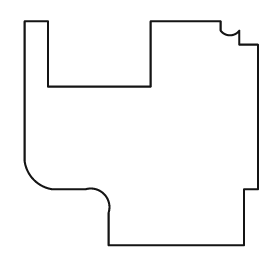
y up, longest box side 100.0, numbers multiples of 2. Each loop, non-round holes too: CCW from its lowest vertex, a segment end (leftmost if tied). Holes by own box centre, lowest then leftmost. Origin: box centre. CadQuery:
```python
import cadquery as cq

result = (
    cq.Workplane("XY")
    .moveTo(-14.0, -48.0)
    .lineTo(44.0, -48.0)
    .lineTo(44.0, -24.0)
    .lineTo(50.0, -24.0)
    .lineTo(50.0, 38.0)
    .lineTo(42.0, 38.0)
    .lineTo(42.0, 44.0)
    .threePointArc((38.0, 42.0), (34.0, 44.0))
    .lineTo(34.0, 48.0)
    .lineTo(4.0, 48.0)
    .lineTo(4.0, 20.0)
    .lineTo(-40.0, 20.0)
    .lineTo(-40.0, 48.0)
    .lineTo(-50.0, 48.0)
    .lineTo(-50.0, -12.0)
    .threePointArc((-46.0, -20.0), (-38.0, -24.0))
    .lineTo(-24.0, -24.0)
    .threePointArc((-16.0, -26.0), (-14.0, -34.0))
    .close()
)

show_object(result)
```